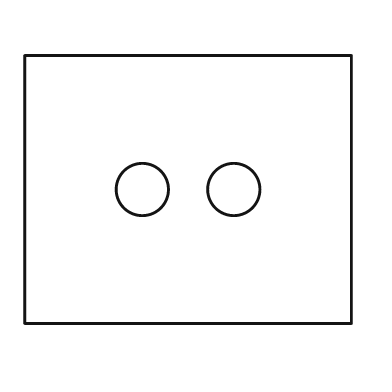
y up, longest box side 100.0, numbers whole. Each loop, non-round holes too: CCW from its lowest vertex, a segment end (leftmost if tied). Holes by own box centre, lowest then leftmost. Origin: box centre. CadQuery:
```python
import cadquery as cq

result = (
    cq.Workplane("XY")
    .moveTo(-50.0, -41.0)
    .lineTo(50.0, -41.0)
    .lineTo(50.0, 41.0)
    .lineTo(-50.0, 41.0)
    .close()
    .moveTo(-14.0, 0.0)
    .circle(8.0)
    .moveTo(14.0, 0.0)
    .circle(8.0)
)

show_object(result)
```